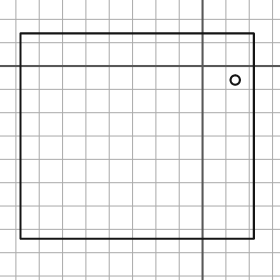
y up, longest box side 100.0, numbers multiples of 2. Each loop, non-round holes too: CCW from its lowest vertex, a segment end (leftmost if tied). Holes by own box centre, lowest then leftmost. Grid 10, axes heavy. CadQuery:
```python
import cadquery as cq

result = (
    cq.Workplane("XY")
    .moveTo(-78.0, -74.0)
    .lineTo(22.0, -74.0)
    .lineTo(22.0, 14.0)
    .lineTo(-78.0, 14.0)
    .close()
    .moveTo(14.0, -6.0)
    .circle(2.0)
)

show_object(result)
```